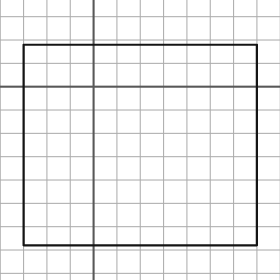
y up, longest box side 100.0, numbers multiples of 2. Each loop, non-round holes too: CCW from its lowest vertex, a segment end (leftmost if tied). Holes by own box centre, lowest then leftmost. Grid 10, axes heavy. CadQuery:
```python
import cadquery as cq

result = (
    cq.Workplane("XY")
    .moveTo(-30.0, -68.0)
    .lineTo(70.0, -68.0)
    .lineTo(70.0, 18.0)
    .lineTo(-30.0, 18.0)
    .close()
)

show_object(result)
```